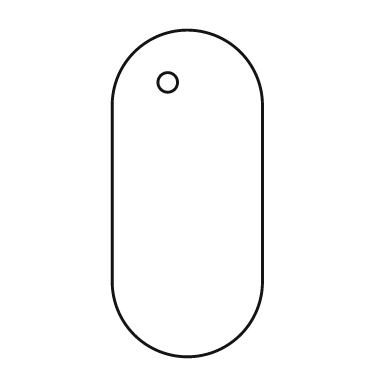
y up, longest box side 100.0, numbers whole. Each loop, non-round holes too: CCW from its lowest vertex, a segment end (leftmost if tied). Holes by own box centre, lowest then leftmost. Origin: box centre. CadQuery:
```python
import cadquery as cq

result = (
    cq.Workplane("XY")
    .moveTo(-23.0, -27.0)
    .threePointArc((0.0, -50.0), (23.0, -27.0))
    .lineTo(23.0, 27.0)
    .threePointArc((0.0, 50.0), (-23.0, 27.0))
    .close()
    .moveTo(-6.0, 34.0)
    .circle(3.0)
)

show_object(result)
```